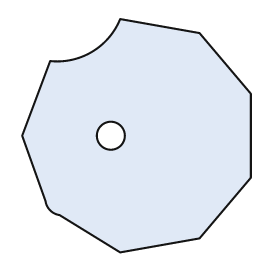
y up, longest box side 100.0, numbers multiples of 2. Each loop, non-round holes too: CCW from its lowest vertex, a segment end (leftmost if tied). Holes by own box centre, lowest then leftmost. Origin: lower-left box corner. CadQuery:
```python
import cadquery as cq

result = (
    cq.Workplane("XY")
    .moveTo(42.0, 0.0)
    .lineTo(76.0, 6.0)
    .lineTo(98.0, 32.0)
    .lineTo(98.0, 68.0)
    .lineTo(76.0, 94.0)
    .lineTo(42.0, 100.0)
    .threePointArc((30.0, 86.0), (12.0, 82.0))
    .lineTo(0.0, 50.0)
    .lineTo(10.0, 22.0)
    .threePointArc((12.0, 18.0), (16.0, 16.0))
    .close()
    .moveTo(38.0, 50.0)
    .circle(6.0)
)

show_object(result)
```